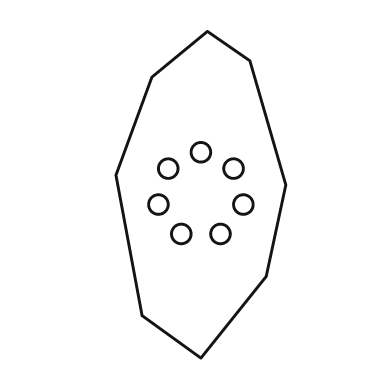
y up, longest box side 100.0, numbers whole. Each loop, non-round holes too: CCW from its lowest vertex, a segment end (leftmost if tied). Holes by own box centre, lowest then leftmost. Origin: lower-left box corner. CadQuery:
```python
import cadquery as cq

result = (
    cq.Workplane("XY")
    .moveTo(26.0, 0.0)
    .lineTo(46.0, 25.0)
    .lineTo(52.0, 53.0)
    .lineTo(41.0, 91.0)
    .lineTo(28.0, 100.0)
    .lineTo(11.0, 86.0)
    .lineTo(0.0, 56.0)
    .lineTo(8.0, 13.0)
    .close()
    .moveTo(20.0, 38.0)
    .circle(3.0)
    .moveTo(32.0, 38.0)
    .circle(3.0)
    .moveTo(13.0, 47.0)
    .circle(3.0)
    .moveTo(39.0, 47.0)
    .circle(3.0)
    .moveTo(16.0, 58.0)
    .circle(3.0)
    .moveTo(36.0, 58.0)
    .circle(3.0)
    .moveTo(26.0, 63.0)
    .circle(3.0)
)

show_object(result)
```